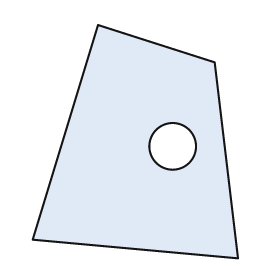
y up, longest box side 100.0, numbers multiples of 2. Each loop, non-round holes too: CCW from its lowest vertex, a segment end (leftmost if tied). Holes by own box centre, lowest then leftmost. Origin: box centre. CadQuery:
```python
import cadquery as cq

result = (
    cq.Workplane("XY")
    .moveTo(44.0, -50.0)
    .lineTo(34.0, 34.0)
    .lineTo(-16.0, 50.0)
    .lineTo(-44.0, -42.0)
    .close()
    .moveTo(16.0, -2.0)
    .circle(10.0)
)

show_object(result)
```